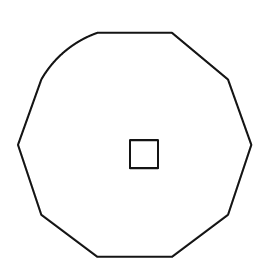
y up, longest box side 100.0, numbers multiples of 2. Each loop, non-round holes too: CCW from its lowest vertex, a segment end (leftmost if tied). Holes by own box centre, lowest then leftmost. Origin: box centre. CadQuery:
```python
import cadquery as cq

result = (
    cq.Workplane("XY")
    .moveTo(-16.0, -48.0)
    .lineTo(16.0, -48.0)
    .lineTo(40.0, -30.0)
    .lineTo(50.0, 0.0)
    .lineTo(40.0, 28.0)
    .lineTo(16.0, 48.0)
    .lineTo(-16.0, 48.0)
    .threePointArc((-30.0, 40.0), (-40.0, 28.0))
    .lineTo(-50.0, 0.0)
    .lineTo(-40.0, -30.0)
    .close()
    .moveTo(-2.0, -10.0)
    .lineTo(10.0, -10.0)
    .lineTo(10.0, 2.0)
    .lineTo(-2.0, 2.0)
    .close()
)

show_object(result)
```